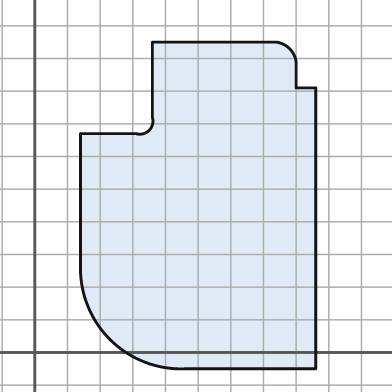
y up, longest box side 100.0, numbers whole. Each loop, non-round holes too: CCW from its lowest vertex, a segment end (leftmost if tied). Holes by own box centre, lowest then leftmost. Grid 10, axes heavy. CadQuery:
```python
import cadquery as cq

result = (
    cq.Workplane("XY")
    .moveTo(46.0, -5.0)
    .lineTo(86.0, -5.0)
    .lineTo(86.0, 81.0)
    .lineTo(80.0, 81.0)
    .lineTo(80.0, 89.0)
    .threePointArc((78.0, 93.0), (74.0, 95.0))
    .lineTo(36.0, 95.0)
    .lineTo(36.0, 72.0)
    .threePointArc((35.0, 68.0), (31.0, 67.0))
    .lineTo(14.0, 67.0)
    .lineTo(14.0, 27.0)
    .threePointArc((23.0, 4.0), (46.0, -5.0))
    .close()
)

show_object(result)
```